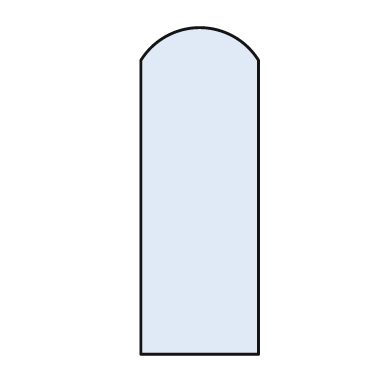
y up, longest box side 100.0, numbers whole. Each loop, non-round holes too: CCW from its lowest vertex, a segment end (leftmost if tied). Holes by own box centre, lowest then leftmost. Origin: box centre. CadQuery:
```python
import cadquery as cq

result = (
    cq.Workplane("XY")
    .moveTo(-18.0, -50.0)
    .lineTo(18.0, -50.0)
    .lineTo(18.0, 40.0)
    .threePointArc((0.0, 50.0), (-18.0, 40.0))
    .close()
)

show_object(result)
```